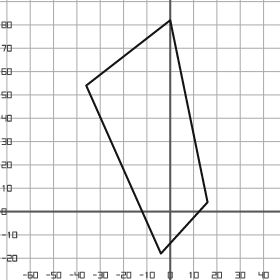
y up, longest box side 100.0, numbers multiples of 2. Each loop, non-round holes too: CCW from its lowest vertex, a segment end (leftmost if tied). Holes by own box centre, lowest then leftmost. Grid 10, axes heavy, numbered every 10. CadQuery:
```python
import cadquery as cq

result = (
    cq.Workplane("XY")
    .moveTo(-4.0, -18.0)
    .lineTo(16.0, 4.0)
    .lineTo(0.0, 82.0)
    .lineTo(-36.0, 54.0)
    .close()
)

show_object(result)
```